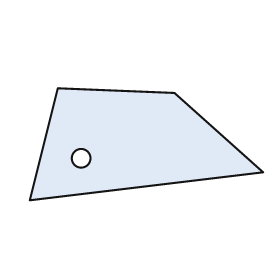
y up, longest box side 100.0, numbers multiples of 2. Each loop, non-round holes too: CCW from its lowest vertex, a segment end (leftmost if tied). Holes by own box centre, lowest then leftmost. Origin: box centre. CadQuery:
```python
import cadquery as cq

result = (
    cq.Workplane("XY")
    .moveTo(-50.0, -24.0)
    .lineTo(50.0, -12.0)
    .lineTo(12.0, 22.0)
    .lineTo(-38.0, 24.0)
    .close()
    .moveTo(-28.0, -6.0)
    .circle(4.0)
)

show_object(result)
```